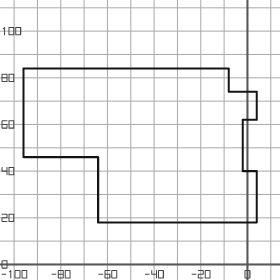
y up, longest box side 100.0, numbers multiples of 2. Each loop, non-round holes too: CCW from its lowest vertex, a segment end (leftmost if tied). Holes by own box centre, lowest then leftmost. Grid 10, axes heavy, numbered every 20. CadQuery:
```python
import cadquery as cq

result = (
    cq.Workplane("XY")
    .moveTo(-64.0, 18.0)
    .lineTo(4.0, 18.0)
    .lineTo(4.0, 40.0)
    .lineTo(-2.0, 40.0)
    .lineTo(-2.0, 62.0)
    .lineTo(4.0, 62.0)
    .lineTo(4.0, 74.0)
    .lineTo(-8.0, 74.0)
    .lineTo(-8.0, 84.0)
    .lineTo(-96.0, 84.0)
    .lineTo(-96.0, 46.0)
    .lineTo(-64.0, 46.0)
    .close()
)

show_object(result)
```